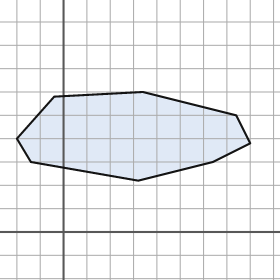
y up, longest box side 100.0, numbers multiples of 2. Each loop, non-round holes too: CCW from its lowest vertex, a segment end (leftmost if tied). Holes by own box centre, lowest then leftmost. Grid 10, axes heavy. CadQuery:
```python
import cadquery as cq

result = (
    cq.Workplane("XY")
    .moveTo(32.0, 22.0)
    .lineTo(64.0, 30.0)
    .lineTo(80.0, 38.0)
    .lineTo(74.0, 50.0)
    .lineTo(34.0, 60.0)
    .lineTo(-4.0, 58.0)
    .lineTo(-20.0, 40.0)
    .lineTo(-14.0, 30.0)
    .close()
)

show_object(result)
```